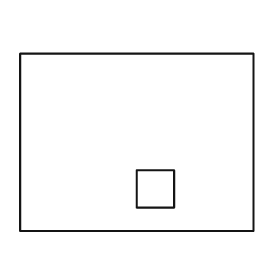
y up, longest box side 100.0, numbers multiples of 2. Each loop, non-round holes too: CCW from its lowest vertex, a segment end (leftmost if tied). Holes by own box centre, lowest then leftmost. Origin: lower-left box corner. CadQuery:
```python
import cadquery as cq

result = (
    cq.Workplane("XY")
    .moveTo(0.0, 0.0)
    .lineTo(100.0, 0.0)
    .lineTo(100.0, 76.0)
    .lineTo(0.0, 76.0)
    .close()
    .moveTo(50.0, 10.0)
    .lineTo(66.0, 10.0)
    .lineTo(66.0, 26.0)
    .lineTo(50.0, 26.0)
    .close()
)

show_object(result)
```